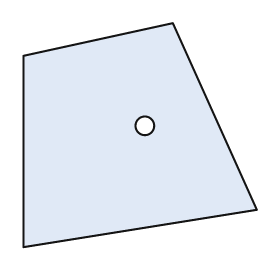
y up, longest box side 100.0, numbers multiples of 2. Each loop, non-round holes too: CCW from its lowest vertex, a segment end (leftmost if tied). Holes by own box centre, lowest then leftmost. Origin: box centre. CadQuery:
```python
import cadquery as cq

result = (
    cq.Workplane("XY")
    .moveTo(-50.0, -48.0)
    .lineTo(50.0, -32.0)
    .lineTo(14.0, 48.0)
    .lineTo(-50.0, 34.0)
    .close()
    .moveTo(2.0, 4.0)
    .circle(4.0)
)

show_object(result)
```